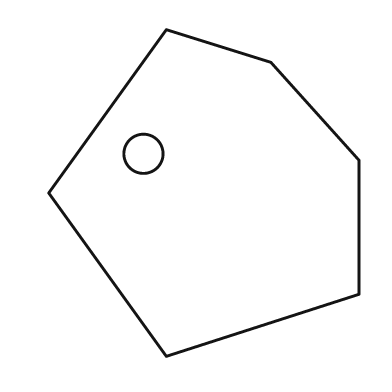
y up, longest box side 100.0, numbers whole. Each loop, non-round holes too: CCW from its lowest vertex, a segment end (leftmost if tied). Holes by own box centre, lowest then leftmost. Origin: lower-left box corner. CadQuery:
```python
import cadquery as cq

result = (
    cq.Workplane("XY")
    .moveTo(36.0, 0.0)
    .lineTo(95.0, 19.0)
    .lineTo(95.0, 60.0)
    .lineTo(68.0, 90.0)
    .lineTo(36.0, 100.0)
    .lineTo(0.0, 50.0)
    .close()
    .moveTo(29.0, 62.0)
    .circle(6.0)
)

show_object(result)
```